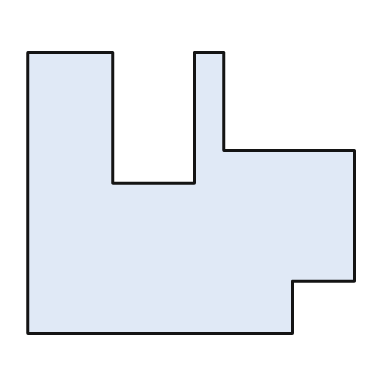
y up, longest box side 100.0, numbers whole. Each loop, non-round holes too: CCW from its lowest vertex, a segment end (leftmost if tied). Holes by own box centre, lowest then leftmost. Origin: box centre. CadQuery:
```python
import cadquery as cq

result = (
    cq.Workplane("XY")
    .moveTo(-50.0, -43.0)
    .lineTo(31.0, -43.0)
    .lineTo(31.0, -27.0)
    .lineTo(50.0, -27.0)
    .lineTo(50.0, 13.0)
    .lineTo(10.0, 13.0)
    .lineTo(10.0, 43.0)
    .lineTo(1.0, 43.0)
    .lineTo(1.0, 3.0)
    .lineTo(-24.0, 3.0)
    .lineTo(-24.0, 43.0)
    .lineTo(-50.0, 43.0)
    .close()
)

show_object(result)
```